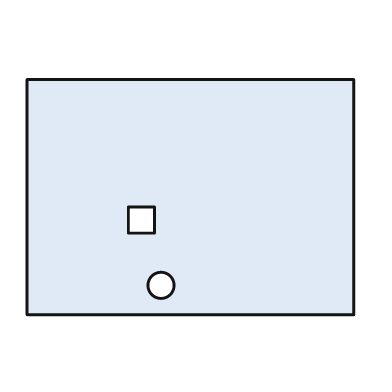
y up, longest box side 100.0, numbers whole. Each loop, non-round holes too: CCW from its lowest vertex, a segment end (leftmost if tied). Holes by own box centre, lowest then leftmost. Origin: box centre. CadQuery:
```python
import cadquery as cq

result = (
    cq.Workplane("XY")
    .moveTo(-50.0, -36.0)
    .lineTo(50.0, -36.0)
    .lineTo(50.0, 36.0)
    .lineTo(-50.0, 36.0)
    .close()
    .moveTo(-9.0, -27.0)
    .circle(4.0)
    .moveTo(-19.0, -11.0)
    .lineTo(-11.0, -11.0)
    .lineTo(-11.0, -3.0)
    .lineTo(-19.0, -3.0)
    .close()
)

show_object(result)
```